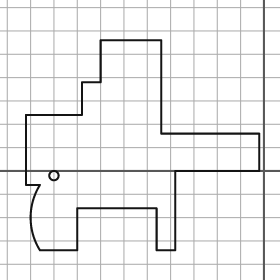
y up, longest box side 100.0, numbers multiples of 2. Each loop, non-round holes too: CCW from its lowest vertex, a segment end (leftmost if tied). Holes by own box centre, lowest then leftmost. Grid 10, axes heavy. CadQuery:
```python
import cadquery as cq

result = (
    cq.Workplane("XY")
    .moveTo(-96.0, -34.0)
    .lineTo(-80.0, -34.0)
    .lineTo(-80.0, -16.0)
    .lineTo(-46.0, -16.0)
    .lineTo(-46.0, -34.0)
    .lineTo(-38.0, -34.0)
    .lineTo(-38.0, 0.0)
    .lineTo(-2.0, 0.0)
    .lineTo(-2.0, 16.0)
    .lineTo(-44.0, 16.0)
    .lineTo(-44.0, 56.0)
    .lineTo(-70.0, 56.0)
    .lineTo(-70.0, 38.0)
    .lineTo(-78.0, 38.0)
    .lineTo(-78.0, 24.0)
    .lineTo(-102.0, 24.0)
    .lineTo(-102.0, -6.0)
    .lineTo(-96.0, -6.0)
    .threePointArc((-100.0, -20.0), (-96.0, -34.0))
    .close()
    .moveTo(-90.0, -2.0)
    .circle(2.0)
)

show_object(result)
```